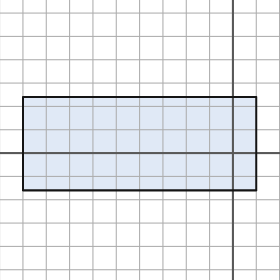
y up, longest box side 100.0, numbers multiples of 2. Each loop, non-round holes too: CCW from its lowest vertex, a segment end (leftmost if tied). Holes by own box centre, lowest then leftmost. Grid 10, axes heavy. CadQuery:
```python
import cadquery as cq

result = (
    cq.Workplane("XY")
    .moveTo(-90.0, -16.0)
    .lineTo(10.0, -16.0)
    .lineTo(10.0, 24.0)
    .lineTo(-90.0, 24.0)
    .close()
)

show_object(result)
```